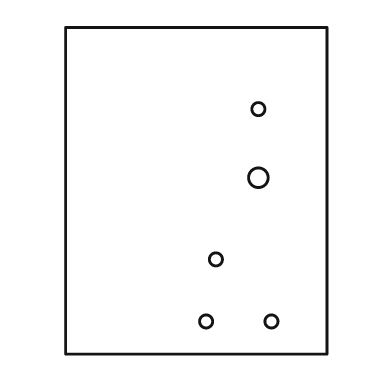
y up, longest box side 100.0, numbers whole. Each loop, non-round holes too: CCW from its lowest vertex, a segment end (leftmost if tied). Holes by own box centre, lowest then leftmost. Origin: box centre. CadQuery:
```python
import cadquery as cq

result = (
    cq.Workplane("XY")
    .moveTo(-40.0, -50.0)
    .lineTo(40.0, -50.0)
    .lineTo(40.0, 50.0)
    .lineTo(-40.0, 50.0)
    .close()
    .moveTo(3.0, -40.0)
    .circle(2.0)
    .moveTo(23.0, -40.0)
    .circle(2.0)
    .moveTo(6.0, -21.0)
    .circle(2.0)
    .moveTo(19.0, 4.0)
    .circle(3.0)
    .moveTo(19.0, 25.0)
    .circle(2.0)
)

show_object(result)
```